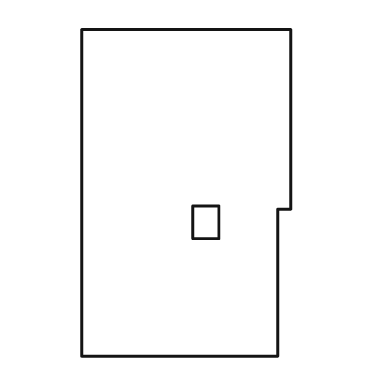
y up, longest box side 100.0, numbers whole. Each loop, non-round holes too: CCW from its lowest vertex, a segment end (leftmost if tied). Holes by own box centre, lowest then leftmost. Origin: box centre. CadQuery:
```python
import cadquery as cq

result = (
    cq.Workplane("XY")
    .moveTo(-32.0, -50.0)
    .lineTo(28.0, -50.0)
    .lineTo(28.0, -5.0)
    .lineTo(32.0, -5.0)
    .lineTo(32.0, 50.0)
    .lineTo(-32.0, 50.0)
    .close()
    .moveTo(2.0, -14.0)
    .lineTo(10.0, -14.0)
    .lineTo(10.0, -4.0)
    .lineTo(2.0, -4.0)
    .close()
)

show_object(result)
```